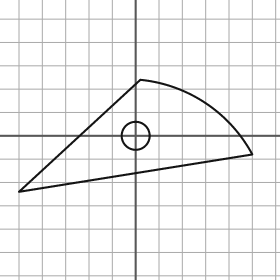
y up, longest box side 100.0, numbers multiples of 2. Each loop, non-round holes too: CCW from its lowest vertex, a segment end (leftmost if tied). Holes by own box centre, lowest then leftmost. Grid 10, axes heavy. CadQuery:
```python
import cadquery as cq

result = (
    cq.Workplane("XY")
    .moveTo(-50.0, -24.0)
    .lineTo(50.0, -8.0)
    .threePointArc((30.0, 14.0), (2.0, 24.0))
    .close()
    .moveTo(0.0, 0.0)
    .circle(6.0)
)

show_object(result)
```